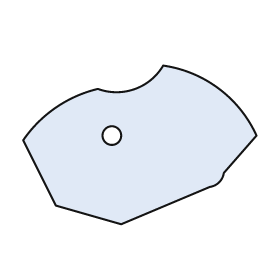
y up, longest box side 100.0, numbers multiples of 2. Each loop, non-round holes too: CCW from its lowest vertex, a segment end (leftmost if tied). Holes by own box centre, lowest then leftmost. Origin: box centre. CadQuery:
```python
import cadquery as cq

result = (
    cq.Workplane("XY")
    .moveTo(-8.0, -34.0)
    .lineTo(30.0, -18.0)
    .threePointArc((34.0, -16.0), (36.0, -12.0))
    .lineTo(50.0, 4.0)
    .threePointArc((34.0, 24.0), (10.0, 34.0))
    .threePointArc((-2.0, 24.0), (-18.0, 24.0))
    .threePointArc((-36.0, 16.0), (-50.0, 2.0))
    .lineTo(-36.0, -26.0)
    .close()
    .moveTo(-12.0, 4.0)
    .circle(4.0)
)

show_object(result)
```